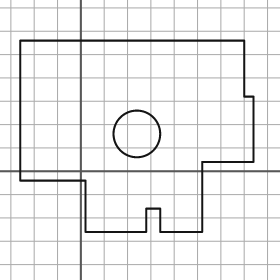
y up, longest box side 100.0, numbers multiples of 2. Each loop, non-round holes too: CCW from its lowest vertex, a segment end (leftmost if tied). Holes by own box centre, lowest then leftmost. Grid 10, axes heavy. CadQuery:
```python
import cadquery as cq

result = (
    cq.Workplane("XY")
    .moveTo(2.0, -26.0)
    .lineTo(28.0, -26.0)
    .lineTo(28.0, -16.0)
    .lineTo(34.0, -16.0)
    .lineTo(34.0, -26.0)
    .lineTo(52.0, -26.0)
    .lineTo(52.0, 4.0)
    .lineTo(74.0, 4.0)
    .lineTo(74.0, 32.0)
    .lineTo(70.0, 32.0)
    .lineTo(70.0, 56.0)
    .lineTo(-26.0, 56.0)
    .lineTo(-26.0, -4.0)
    .lineTo(2.0, -4.0)
    .close()
    .moveTo(24.0, 16.0)
    .circle(10.0)
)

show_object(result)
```